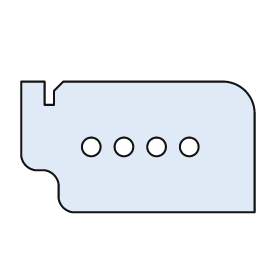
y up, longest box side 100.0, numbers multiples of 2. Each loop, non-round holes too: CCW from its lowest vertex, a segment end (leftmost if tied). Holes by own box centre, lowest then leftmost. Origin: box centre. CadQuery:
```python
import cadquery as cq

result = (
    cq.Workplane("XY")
    .moveTo(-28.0, -28.0)
    .lineTo(50.0, -28.0)
    .lineTo(50.0, 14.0)
    .threePointArc((46.0, 24.0), (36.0, 28.0))
    .lineTo(-32.0, 28.0)
    .lineTo(-36.0, 24.0)
    .lineTo(-36.0, 18.0)
    .lineTo(-40.0, 18.0)
    .lineTo(-40.0, 28.0)
    .lineTo(-50.0, 28.0)
    .lineTo(-50.0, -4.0)
    .threePointArc((-48.0, -8.0), (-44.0, -10.0))
    .lineTo(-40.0, -10.0)
    .threePointArc((-36.0, -12.0), (-34.0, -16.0))
    .lineTo(-34.0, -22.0)
    .threePointArc((-32.0, -26.0), (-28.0, -28.0))
    .close()
    .moveTo(-20.0, 0.0)
    .circle(4.0)
    .moveTo(-6.0, 0.0)
    .circle(4.0)
    .moveTo(8.0, 0.0)
    .circle(4.0)
    .moveTo(22.0, 0.0)
    .circle(4.0)
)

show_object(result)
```